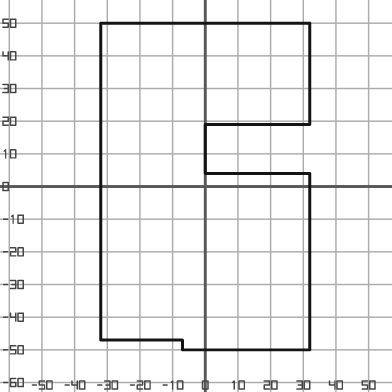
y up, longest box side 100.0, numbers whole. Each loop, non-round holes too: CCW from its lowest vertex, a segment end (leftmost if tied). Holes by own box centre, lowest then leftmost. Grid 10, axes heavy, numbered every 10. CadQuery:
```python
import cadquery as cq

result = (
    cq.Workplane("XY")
    .moveTo(-7.0, -50.0)
    .lineTo(32.0, -50.0)
    .lineTo(32.0, 4.0)
    .lineTo(0.0, 4.0)
    .lineTo(0.0, 19.0)
    .lineTo(32.0, 19.0)
    .lineTo(32.0, 50.0)
    .lineTo(-32.0, 50.0)
    .lineTo(-32.0, -47.0)
    .lineTo(-7.0, -47.0)
    .close()
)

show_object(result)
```